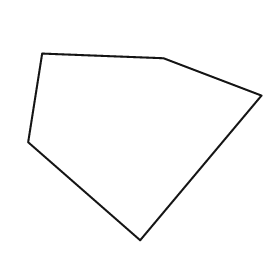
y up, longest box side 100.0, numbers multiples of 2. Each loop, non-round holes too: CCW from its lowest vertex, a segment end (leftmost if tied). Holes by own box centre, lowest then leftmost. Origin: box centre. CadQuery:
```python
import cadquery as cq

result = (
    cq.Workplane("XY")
    .moveTo(-2.0, -40.0)
    .lineTo(50.0, 22.0)
    .lineTo(8.0, 38.0)
    .lineTo(-44.0, 40.0)
    .lineTo(-50.0, 2.0)
    .close()
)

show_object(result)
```